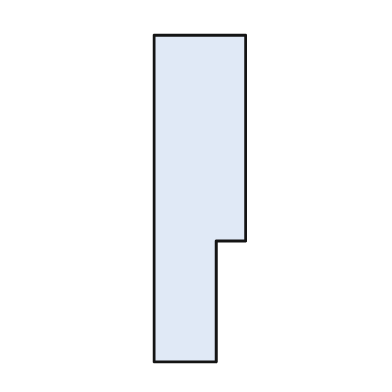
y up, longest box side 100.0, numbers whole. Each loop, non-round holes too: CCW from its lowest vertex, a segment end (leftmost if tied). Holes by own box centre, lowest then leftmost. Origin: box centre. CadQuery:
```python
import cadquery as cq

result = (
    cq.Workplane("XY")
    .moveTo(-14.0, -50.0)
    .lineTo(5.0, -50.0)
    .lineTo(5.0, -13.0)
    .lineTo(14.0, -13.0)
    .lineTo(14.0, 50.0)
    .lineTo(-14.0, 50.0)
    .close()
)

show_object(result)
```